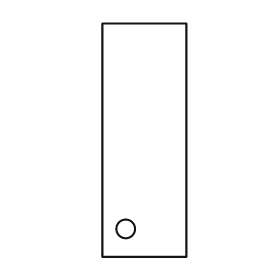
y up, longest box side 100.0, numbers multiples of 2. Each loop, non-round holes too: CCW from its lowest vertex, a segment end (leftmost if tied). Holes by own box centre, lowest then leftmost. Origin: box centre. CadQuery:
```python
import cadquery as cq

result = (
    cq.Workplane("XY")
    .moveTo(-18.0, -50.0)
    .lineTo(18.0, -50.0)
    .lineTo(18.0, 50.0)
    .lineTo(-18.0, 50.0)
    .close()
    .moveTo(-8.0, -38.0)
    .circle(4.0)
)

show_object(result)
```